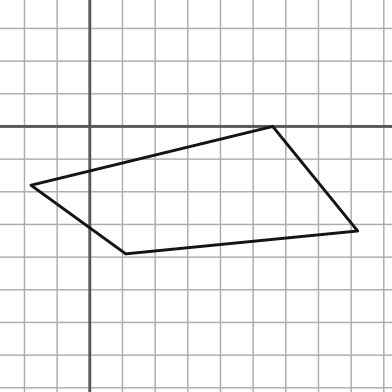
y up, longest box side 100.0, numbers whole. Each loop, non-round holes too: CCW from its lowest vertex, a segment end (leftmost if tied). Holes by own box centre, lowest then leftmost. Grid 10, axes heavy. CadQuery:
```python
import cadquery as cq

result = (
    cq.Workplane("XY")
    .moveTo(11.0, -39.0)
    .lineTo(82.0, -32.0)
    .lineTo(56.0, 0.0)
    .lineTo(-18.0, -18.0)
    .close()
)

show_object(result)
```